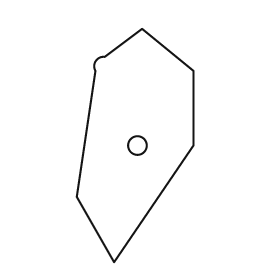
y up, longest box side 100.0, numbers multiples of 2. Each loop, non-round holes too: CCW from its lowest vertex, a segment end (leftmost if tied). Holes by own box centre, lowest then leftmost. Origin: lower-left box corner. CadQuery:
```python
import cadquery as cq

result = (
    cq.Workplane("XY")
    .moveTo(16.0, 0.0)
    .lineTo(50.0, 50.0)
    .lineTo(50.0, 82.0)
    .lineTo(28.0, 100.0)
    .lineTo(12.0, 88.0)
    .threePointArc((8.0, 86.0), (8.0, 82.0))
    .lineTo(0.0, 28.0)
    .close()
    .moveTo(26.0, 50.0)
    .circle(4.0)
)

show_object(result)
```